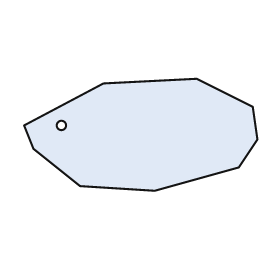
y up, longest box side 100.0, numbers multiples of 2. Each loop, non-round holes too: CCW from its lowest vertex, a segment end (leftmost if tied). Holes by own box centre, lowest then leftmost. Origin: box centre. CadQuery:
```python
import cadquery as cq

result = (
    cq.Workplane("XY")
    .moveTo(6.0, -24.0)
    .lineTo(42.0, -14.0)
    .lineTo(50.0, -2.0)
    .lineTo(48.0, 12.0)
    .lineTo(24.0, 24.0)
    .lineTo(-16.0, 22.0)
    .lineTo(-50.0, 4.0)
    .lineTo(-46.0, -6.0)
    .lineTo(-26.0, -22.0)
    .close()
    .moveTo(-34.0, 4.0)
    .circle(2.0)
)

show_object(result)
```